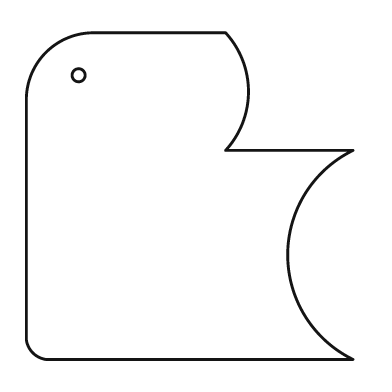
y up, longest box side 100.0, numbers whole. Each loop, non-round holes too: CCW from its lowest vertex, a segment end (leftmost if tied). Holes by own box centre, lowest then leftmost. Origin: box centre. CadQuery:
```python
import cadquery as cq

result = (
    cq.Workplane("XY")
    .moveTo(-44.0, -50.0)
    .lineTo(50.0, -50.0)
    .threePointArc((30.0, -18.0), (50.0, 14.0))
    .lineTo(11.0, 14.0)
    .threePointArc((18.0, 32.0), (11.0, 50.0))
    .lineTo(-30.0, 50.0)
    .threePointArc((-44.0, 44.0), (-50.0, 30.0))
    .lineTo(-50.0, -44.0)
    .threePointArc((-48.0, -48.0), (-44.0, -50.0))
    .close()
    .moveTo(-34.0, 37.0)
    .circle(2.0)
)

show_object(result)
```